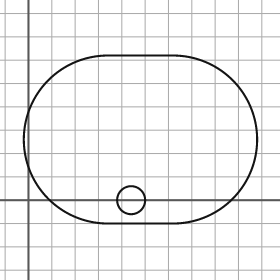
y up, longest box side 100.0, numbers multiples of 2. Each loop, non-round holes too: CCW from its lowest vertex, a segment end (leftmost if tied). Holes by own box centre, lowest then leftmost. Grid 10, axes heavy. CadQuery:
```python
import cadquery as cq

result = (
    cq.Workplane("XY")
    .moveTo(34.0, -10.0)
    .lineTo(62.0, -10.0)
    .threePointArc((98.0, 26.0), (62.0, 62.0))
    .lineTo(34.0, 62.0)
    .threePointArc((-2.0, 26.0), (34.0, -10.0))
    .close()
    .moveTo(44.0, 0.0)
    .circle(6.0)
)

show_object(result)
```